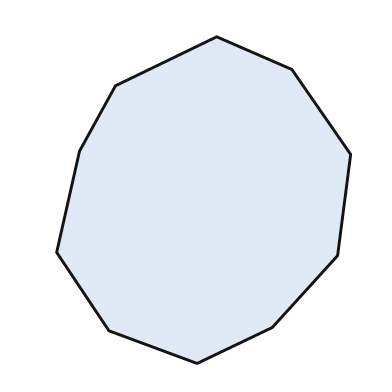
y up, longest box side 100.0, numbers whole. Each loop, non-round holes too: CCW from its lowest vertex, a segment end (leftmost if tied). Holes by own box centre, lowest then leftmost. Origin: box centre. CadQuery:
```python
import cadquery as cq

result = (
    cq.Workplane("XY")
    .moveTo(-2.0, -50.0)
    .lineTo(21.0, -39.0)
    .lineTo(41.0, -17.0)
    .lineTo(45.0, 14.0)
    .lineTo(27.0, 40.0)
    .lineTo(4.0, 50.0)
    .lineTo(-27.0, 35.0)
    .lineTo(-38.0, 15.0)
    .lineTo(-45.0, -16.0)
    .lineTo(-29.0, -40.0)
    .close()
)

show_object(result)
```